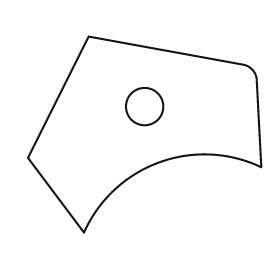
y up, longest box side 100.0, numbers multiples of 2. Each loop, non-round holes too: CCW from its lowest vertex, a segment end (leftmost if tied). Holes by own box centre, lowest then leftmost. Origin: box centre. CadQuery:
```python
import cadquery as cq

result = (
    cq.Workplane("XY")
    .moveTo(-26.0, -42.0)
    .threePointArc((6.0, -12.0), (50.0, -14.0))
    .lineTo(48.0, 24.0)
    .threePointArc((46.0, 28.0), (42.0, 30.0))
    .lineTo(-24.0, 42.0)
    .lineTo(-50.0, -10.0)
    .close()
    .moveTo(0.0, 12.0)
    .circle(8.0)
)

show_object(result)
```